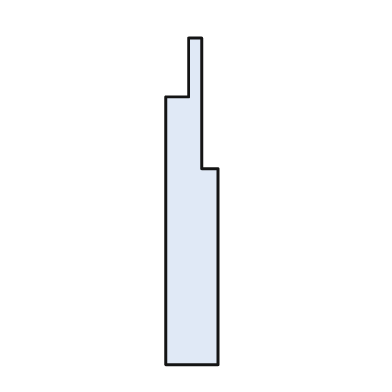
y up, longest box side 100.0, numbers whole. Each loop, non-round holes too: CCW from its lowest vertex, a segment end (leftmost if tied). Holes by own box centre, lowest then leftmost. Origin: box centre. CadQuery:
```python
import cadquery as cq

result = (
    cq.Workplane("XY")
    .moveTo(-8.0, -50.0)
    .lineTo(8.0, -50.0)
    .lineTo(8.0, 10.0)
    .lineTo(3.0, 10.0)
    .lineTo(3.0, 50.0)
    .lineTo(-1.0, 50.0)
    .lineTo(-1.0, 32.0)
    .lineTo(-8.0, 32.0)
    .close()
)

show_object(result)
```